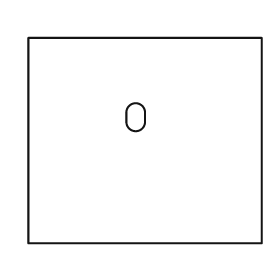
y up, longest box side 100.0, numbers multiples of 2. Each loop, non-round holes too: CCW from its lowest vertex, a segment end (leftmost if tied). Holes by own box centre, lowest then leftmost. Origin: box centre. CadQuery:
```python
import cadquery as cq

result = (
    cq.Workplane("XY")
    .moveTo(-50.0, -44.0)
    .lineTo(50.0, -44.0)
    .lineTo(50.0, 44.0)
    .lineTo(-50.0, 44.0)
    .close()
    .moveTo(-8.0, 8.0)
    .threePointArc((-4.0, 4.0), (0.0, 8.0))
    .lineTo(0.0, 12.0)
    .threePointArc((-4.0, 16.0), (-8.0, 12.0))
    .close()
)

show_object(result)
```